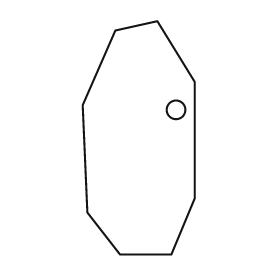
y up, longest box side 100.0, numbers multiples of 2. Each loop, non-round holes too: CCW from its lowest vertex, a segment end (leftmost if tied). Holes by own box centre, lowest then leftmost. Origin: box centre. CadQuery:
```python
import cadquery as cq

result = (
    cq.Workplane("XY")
    .moveTo(-8.0, -50.0)
    .lineTo(14.0, -50.0)
    .lineTo(24.0, -26.0)
    .lineTo(24.0, 24.0)
    .lineTo(8.0, 50.0)
    .lineTo(-10.0, 46.0)
    .lineTo(-24.0, 14.0)
    .lineTo(-22.0, -32.0)
    .close()
    .moveTo(16.0, 12.0)
    .circle(4.0)
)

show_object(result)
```